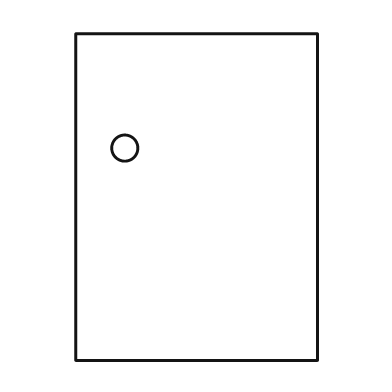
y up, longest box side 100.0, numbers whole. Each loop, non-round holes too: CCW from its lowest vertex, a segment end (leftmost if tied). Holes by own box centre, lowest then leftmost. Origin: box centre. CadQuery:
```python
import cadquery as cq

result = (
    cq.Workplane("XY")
    .moveTo(-37.0, -50.0)
    .lineTo(37.0, -50.0)
    .lineTo(37.0, 50.0)
    .lineTo(-37.0, 50.0)
    .close()
    .moveTo(-22.0, 15.0)
    .circle(4.0)
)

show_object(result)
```